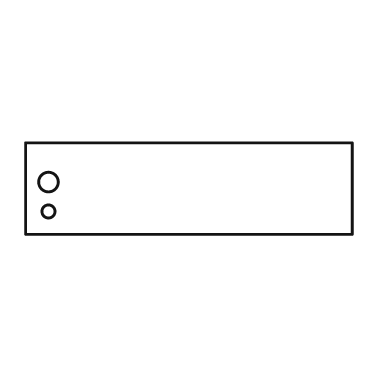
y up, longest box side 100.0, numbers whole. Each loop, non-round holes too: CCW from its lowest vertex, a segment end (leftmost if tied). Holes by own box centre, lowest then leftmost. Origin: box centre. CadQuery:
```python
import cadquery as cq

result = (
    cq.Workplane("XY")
    .moveTo(-50.0, -14.0)
    .lineTo(50.0, -14.0)
    .lineTo(50.0, 14.0)
    .lineTo(-50.0, 14.0)
    .close()
    .moveTo(-43.0, -7.0)
    .circle(2.0)
    .moveTo(-43.0, 2.0)
    .circle(3.0)
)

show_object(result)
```